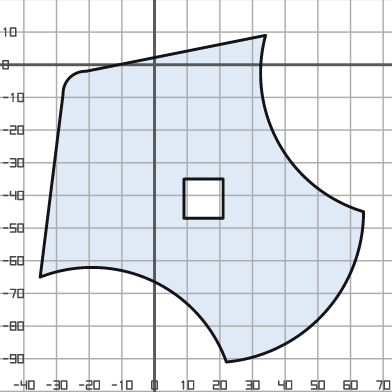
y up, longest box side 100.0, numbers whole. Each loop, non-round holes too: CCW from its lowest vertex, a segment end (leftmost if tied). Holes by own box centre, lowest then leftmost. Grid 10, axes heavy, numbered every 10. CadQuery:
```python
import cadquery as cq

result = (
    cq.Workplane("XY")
    .moveTo(22.0, -91.0)
    .threePointArc((52.0, -76.0), (64.0, -45.0))
    .threePointArc((38.0, -24.0), (34.0, 9.0))
    .lineTo(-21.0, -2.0)
    .threePointArc((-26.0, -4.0), (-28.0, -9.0))
    .lineTo(-35.0, -65.0)
    .threePointArc((-1.0, -66.0), (22.0, -91.0))
    .close()
    .moveTo(9.0, -47.0)
    .lineTo(21.0, -47.0)
    .lineTo(21.0, -35.0)
    .lineTo(9.0, -35.0)
    .close()
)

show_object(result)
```